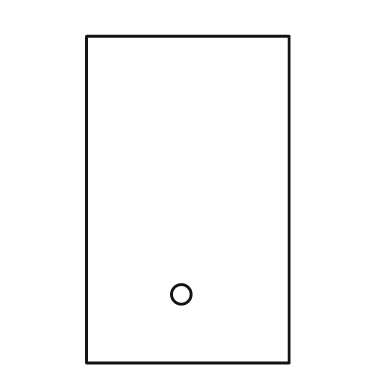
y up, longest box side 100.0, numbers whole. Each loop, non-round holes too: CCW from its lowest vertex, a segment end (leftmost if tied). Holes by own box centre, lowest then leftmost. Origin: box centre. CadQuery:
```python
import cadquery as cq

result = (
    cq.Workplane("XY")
    .moveTo(-31.0, -50.0)
    .lineTo(31.0, -50.0)
    .lineTo(31.0, 50.0)
    .lineTo(-31.0, 50.0)
    .close()
    .moveTo(-2.0, -29.0)
    .circle(3.0)
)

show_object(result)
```